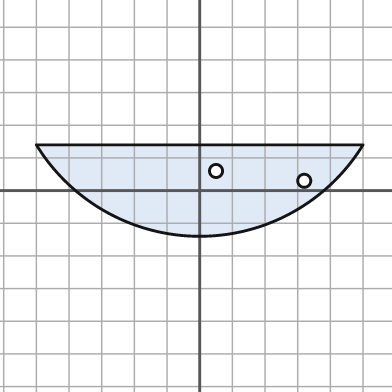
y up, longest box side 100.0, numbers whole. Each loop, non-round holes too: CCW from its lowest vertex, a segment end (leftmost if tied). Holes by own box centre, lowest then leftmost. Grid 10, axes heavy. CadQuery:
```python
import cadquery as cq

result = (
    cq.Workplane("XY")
    .moveTo(-50.0, 14.0)
    .threePointArc((0.0, -14.0), (50.0, 14.0))
    .close()
    .moveTo(32.0, 3.0)
    .circle(2.0)
    .moveTo(5.0, 6.0)
    .circle(2.0)
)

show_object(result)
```